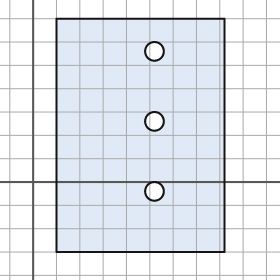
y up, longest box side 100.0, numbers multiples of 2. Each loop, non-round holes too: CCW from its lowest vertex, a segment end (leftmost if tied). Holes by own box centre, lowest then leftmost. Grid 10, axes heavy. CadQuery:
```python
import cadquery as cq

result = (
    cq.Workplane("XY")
    .moveTo(10.0, -30.0)
    .lineTo(82.0, -30.0)
    .lineTo(82.0, 70.0)
    .lineTo(10.0, 70.0)
    .close()
    .moveTo(52.0, -4.0)
    .circle(4.0)
    .moveTo(52.0, 26.0)
    .circle(4.0)
    .moveTo(52.0, 56.0)
    .circle(4.0)
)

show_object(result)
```